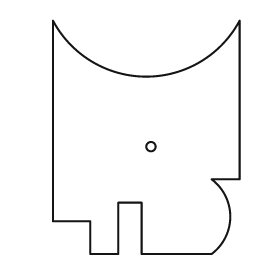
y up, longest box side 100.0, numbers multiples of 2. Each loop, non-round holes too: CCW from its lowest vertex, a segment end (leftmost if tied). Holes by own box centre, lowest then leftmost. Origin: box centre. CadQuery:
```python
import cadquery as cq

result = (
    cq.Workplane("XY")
    .moveTo(-24.0, -50.0)
    .lineTo(-12.0, -50.0)
    .lineTo(-12.0, -28.0)
    .lineTo(-2.0, -28.0)
    .lineTo(-2.0, -50.0)
    .lineTo(28.0, -50.0)
    .threePointArc((36.0, -34.0), (28.0, -18.0))
    .lineTo(40.0, -18.0)
    .lineTo(40.0, 50.0)
    .threePointArc((0.0, 26.0), (-40.0, 50.0))
    .lineTo(-40.0, -36.0)
    .lineTo(-24.0, -36.0)
    .close()
    .moveTo(2.0, -4.0)
    .circle(2.0)
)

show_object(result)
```